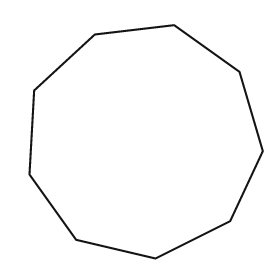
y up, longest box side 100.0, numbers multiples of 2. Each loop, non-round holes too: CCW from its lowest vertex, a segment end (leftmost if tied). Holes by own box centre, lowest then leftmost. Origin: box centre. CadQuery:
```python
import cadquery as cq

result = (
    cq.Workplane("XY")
    .moveTo(4.0, -50.0)
    .lineTo(36.0, -34.0)
    .lineTo(50.0, -4.0)
    .lineTo(40.0, 30.0)
    .lineTo(12.0, 50.0)
    .lineTo(-22.0, 46.0)
    .lineTo(-48.0, 22.0)
    .lineTo(-50.0, -14.0)
    .lineTo(-30.0, -42.0)
    .close()
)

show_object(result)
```